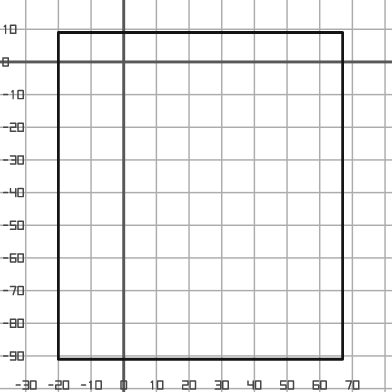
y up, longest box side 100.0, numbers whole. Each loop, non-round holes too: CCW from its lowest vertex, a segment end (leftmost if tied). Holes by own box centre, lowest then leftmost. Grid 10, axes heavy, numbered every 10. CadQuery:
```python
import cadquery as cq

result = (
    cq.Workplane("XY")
    .moveTo(-20.0, -91.0)
    .lineTo(67.0, -91.0)
    .lineTo(67.0, 9.0)
    .lineTo(-20.0, 9.0)
    .close()
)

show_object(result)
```